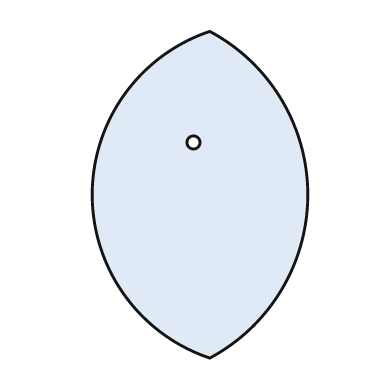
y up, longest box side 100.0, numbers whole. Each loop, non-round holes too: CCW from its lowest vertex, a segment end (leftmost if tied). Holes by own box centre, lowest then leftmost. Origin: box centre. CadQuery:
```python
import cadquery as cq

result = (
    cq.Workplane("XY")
    .moveTo(3.0, -50.0)
    .threePointArc((33.0, 0.0), (3.0, 50.0))
    .threePointArc((-33.0, 0.0), (3.0, -50.0))
    .close()
    .moveTo(-2.0, 16.0)
    .circle(2.0)
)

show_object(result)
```